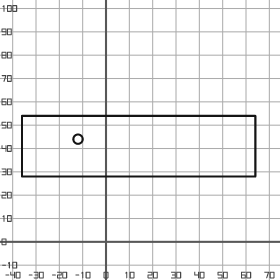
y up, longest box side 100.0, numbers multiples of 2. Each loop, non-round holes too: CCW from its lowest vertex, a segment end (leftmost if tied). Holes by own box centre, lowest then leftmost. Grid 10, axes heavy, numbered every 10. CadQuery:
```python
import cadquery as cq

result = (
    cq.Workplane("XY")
    .moveTo(-36.0, 28.0)
    .lineTo(64.0, 28.0)
    .lineTo(64.0, 54.0)
    .lineTo(-36.0, 54.0)
    .close()
    .moveTo(-12.0, 44.0)
    .circle(2.0)
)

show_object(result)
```